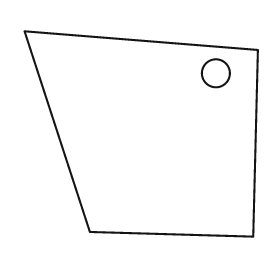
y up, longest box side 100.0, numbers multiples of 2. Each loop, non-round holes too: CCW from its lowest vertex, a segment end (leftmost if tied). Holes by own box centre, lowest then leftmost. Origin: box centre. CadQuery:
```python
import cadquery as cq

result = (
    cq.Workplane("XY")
    .moveTo(48.0, -44.0)
    .lineTo(50.0, 36.0)
    .lineTo(-50.0, 44.0)
    .lineTo(-22.0, -42.0)
    .close()
    .moveTo(32.0, 26.0)
    .circle(6.0)
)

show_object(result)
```